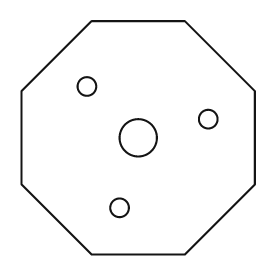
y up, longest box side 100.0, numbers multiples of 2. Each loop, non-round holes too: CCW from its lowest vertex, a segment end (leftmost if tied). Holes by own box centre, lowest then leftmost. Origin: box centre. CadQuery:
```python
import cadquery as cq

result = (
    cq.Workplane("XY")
    .moveTo(-20.0, -50.0)
    .lineTo(20.0, -50.0)
    .lineTo(50.0, -20.0)
    .lineTo(50.0, 20.0)
    .lineTo(20.0, 50.0)
    .lineTo(-20.0, 50.0)
    .lineTo(-50.0, 20.0)
    .lineTo(-50.0, -20.0)
    .close()
    .moveTo(-8.0, -30.0)
    .circle(4.0)
    .moveTo(0.0, 0.0)
    .circle(8.0)
    .moveTo(30.0, 8.0)
    .circle(4.0)
    .moveTo(-22.0, 22.0)
    .circle(4.0)
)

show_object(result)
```